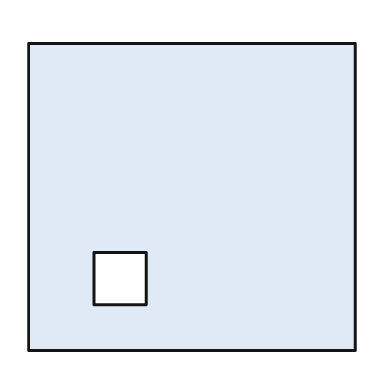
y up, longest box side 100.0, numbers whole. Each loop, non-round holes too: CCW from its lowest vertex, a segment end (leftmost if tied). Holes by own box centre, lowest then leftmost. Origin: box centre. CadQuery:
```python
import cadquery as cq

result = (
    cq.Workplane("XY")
    .moveTo(-50.0, -47.0)
    .lineTo(50.0, -47.0)
    .lineTo(50.0, 47.0)
    .lineTo(-50.0, 47.0)
    .close()
    .moveTo(-30.0, -33.0)
    .lineTo(-14.0, -33.0)
    .lineTo(-14.0, -17.0)
    .lineTo(-30.0, -17.0)
    .close()
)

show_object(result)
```